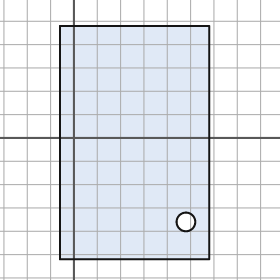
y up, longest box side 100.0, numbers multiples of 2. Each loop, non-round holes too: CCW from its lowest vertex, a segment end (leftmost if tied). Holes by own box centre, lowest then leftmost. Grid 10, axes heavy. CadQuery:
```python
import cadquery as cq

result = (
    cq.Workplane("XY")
    .moveTo(-6.0, -52.0)
    .lineTo(58.0, -52.0)
    .lineTo(58.0, 48.0)
    .lineTo(-6.0, 48.0)
    .close()
    .moveTo(48.0, -36.0)
    .circle(4.0)
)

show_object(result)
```